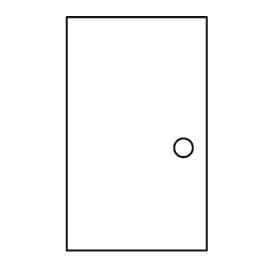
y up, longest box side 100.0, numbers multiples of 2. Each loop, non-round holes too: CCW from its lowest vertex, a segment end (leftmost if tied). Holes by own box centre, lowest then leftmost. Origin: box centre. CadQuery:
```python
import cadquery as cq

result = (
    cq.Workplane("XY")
    .moveTo(-30.0, -50.0)
    .lineTo(30.0, -50.0)
    .lineTo(30.0, 50.0)
    .lineTo(-30.0, 50.0)
    .close()
    .moveTo(20.0, -6.0)
    .circle(4.0)
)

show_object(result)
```